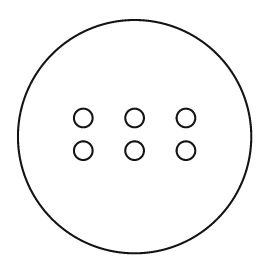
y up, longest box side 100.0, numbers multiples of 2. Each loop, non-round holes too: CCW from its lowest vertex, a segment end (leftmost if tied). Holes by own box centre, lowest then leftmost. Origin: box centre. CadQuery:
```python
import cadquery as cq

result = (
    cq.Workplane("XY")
    .moveTo(0.0, 0.0)
    .circle(50.0)
    .moveTo(-22.0, -6.0)
    .circle(4.0)
    .moveTo(0.0, -6.0)
    .circle(4.0)
    .moveTo(22.0, -6.0)
    .circle(4.0)
    .moveTo(-22.0, 8.0)
    .circle(4.0)
    .moveTo(0.0, 8.0)
    .circle(4.0)
    .moveTo(22.0, 8.0)
    .circle(4.0)
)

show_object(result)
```